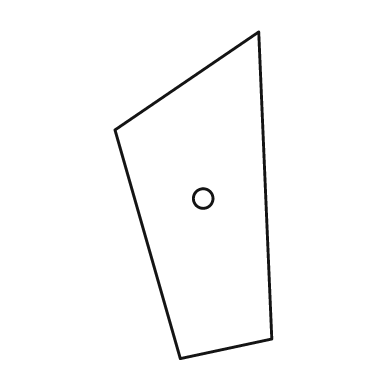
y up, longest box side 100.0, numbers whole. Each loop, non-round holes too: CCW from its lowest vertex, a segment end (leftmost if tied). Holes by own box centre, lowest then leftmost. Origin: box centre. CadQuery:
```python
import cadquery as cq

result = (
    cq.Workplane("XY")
    .moveTo(-4.0, -50.0)
    .lineTo(24.0, -44.0)
    .lineTo(20.0, 50.0)
    .lineTo(-24.0, 20.0)
    .close()
    .moveTo(3.0, -1.0)
    .circle(3.0)
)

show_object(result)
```